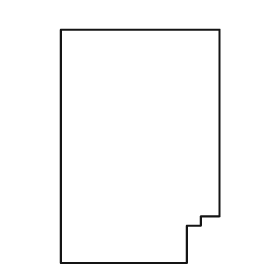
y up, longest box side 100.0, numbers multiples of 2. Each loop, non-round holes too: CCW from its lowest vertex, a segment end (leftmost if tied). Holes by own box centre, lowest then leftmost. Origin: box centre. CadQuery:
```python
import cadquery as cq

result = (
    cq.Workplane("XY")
    .moveTo(-34.0, -50.0)
    .lineTo(20.0, -50.0)
    .lineTo(20.0, -34.0)
    .lineTo(26.0, -34.0)
    .lineTo(26.0, -30.0)
    .lineTo(34.0, -30.0)
    .lineTo(34.0, 50.0)
    .lineTo(-34.0, 50.0)
    .close()
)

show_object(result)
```